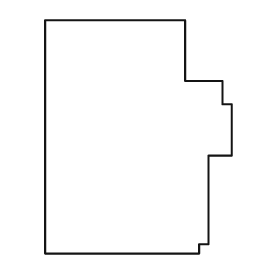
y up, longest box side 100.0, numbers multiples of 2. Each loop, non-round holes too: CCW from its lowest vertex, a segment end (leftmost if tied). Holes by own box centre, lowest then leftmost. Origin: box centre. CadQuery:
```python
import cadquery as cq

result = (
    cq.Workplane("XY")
    .moveTo(-40.0, -50.0)
    .lineTo(26.0, -50.0)
    .lineTo(26.0, -46.0)
    .lineTo(30.0, -46.0)
    .lineTo(30.0, -8.0)
    .lineTo(40.0, -8.0)
    .lineTo(40.0, 14.0)
    .lineTo(36.0, 14.0)
    .lineTo(36.0, 24.0)
    .lineTo(20.0, 24.0)
    .lineTo(20.0, 50.0)
    .lineTo(-40.0, 50.0)
    .close()
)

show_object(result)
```